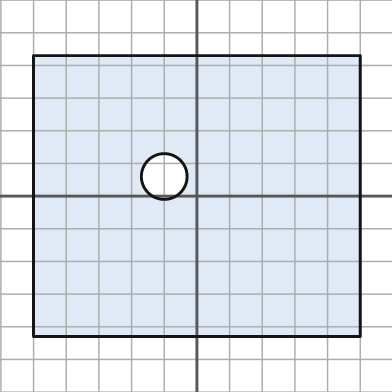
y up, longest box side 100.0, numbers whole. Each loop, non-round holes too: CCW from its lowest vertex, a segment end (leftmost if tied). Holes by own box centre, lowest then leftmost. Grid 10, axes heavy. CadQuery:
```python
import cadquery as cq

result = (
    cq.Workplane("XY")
    .moveTo(-50.0, -43.0)
    .lineTo(50.0, -43.0)
    .lineTo(50.0, 43.0)
    .lineTo(-50.0, 43.0)
    .close()
    .moveTo(-10.0, 6.0)
    .circle(7.0)
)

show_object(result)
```